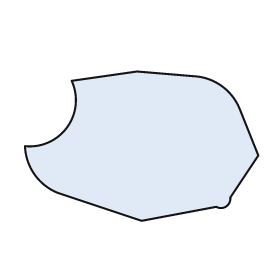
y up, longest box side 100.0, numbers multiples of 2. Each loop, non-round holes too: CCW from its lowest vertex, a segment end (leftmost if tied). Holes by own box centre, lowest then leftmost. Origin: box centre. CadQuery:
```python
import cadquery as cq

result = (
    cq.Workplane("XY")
    .moveTo(0.0, -32.0)
    .lineTo(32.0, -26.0)
    .threePointArc((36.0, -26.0), (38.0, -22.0))
    .lineTo(50.0, -4.0)
    .lineTo(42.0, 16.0)
    .threePointArc((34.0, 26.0), (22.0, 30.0))
    .lineTo(-2.0, 32.0)
    .lineTo(-30.0, 28.0)
    .threePointArc((-32.0, 8.0), (-50.0, 0.0))
    .threePointArc((-46.0, -12.0), (-36.0, -20.0))
    .close()
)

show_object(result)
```